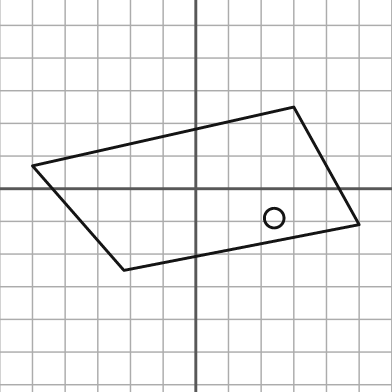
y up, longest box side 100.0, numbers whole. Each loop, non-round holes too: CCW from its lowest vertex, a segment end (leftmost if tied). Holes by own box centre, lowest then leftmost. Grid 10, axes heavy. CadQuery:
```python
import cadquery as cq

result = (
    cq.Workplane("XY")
    .moveTo(-22.0, -25.0)
    .lineTo(50.0, -11.0)
    .lineTo(30.0, 25.0)
    .lineTo(-50.0, 7.0)
    .close()
    .moveTo(24.0, -9.0)
    .circle(3.0)
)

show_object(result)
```